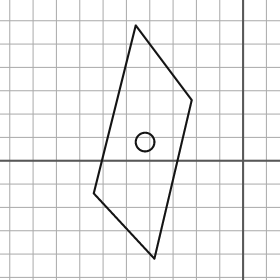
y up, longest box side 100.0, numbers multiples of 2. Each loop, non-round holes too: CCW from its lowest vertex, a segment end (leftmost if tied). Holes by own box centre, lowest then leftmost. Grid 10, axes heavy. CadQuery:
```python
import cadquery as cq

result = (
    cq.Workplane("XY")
    .moveTo(-38.0, -42.0)
    .lineTo(-22.0, 26.0)
    .lineTo(-46.0, 58.0)
    .lineTo(-64.0, -14.0)
    .close()
    .moveTo(-42.0, 8.0)
    .circle(4.0)
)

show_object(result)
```